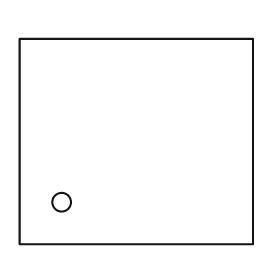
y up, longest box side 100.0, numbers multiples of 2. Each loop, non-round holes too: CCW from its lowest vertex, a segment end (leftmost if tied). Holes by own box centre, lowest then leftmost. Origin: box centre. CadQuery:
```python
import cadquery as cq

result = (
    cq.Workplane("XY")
    .moveTo(-50.0, -44.0)
    .lineTo(50.0, -44.0)
    .lineTo(50.0, 44.0)
    .lineTo(-50.0, 44.0)
    .close()
    .moveTo(-32.0, -26.0)
    .circle(4.0)
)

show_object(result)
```